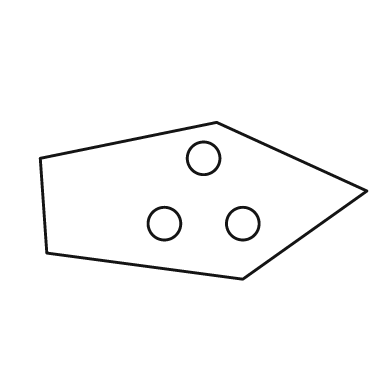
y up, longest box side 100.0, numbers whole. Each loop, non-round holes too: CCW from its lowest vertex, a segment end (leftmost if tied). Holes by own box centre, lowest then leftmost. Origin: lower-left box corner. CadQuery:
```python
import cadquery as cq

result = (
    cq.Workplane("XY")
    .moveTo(62.0, 0.0)
    .lineTo(100.0, 27.0)
    .lineTo(54.0, 48.0)
    .lineTo(0.0, 37.0)
    .lineTo(2.0, 8.0)
    .close()
    .moveTo(38.0, 17.0)
    .circle(5.0)
    .moveTo(62.0, 17.0)
    .circle(5.0)
    .moveTo(50.0, 37.0)
    .circle(5.0)
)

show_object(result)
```